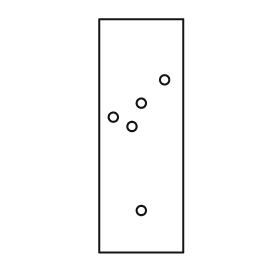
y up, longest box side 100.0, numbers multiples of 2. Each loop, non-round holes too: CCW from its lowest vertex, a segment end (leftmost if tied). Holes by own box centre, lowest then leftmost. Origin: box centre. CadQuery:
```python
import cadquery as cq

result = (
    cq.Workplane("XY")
    .moveTo(-18.0, -50.0)
    .lineTo(18.0, -50.0)
    .lineTo(18.0, 50.0)
    .lineTo(-18.0, 50.0)
    .close()
    .moveTo(0.0, -32.0)
    .circle(2.0)
    .moveTo(-4.0, 4.0)
    .circle(2.0)
    .moveTo(-12.0, 8.0)
    .circle(2.0)
    .moveTo(0.0, 14.0)
    .circle(2.0)
    .moveTo(10.0, 24.0)
    .circle(2.0)
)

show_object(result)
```